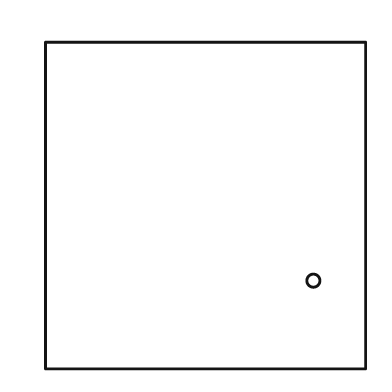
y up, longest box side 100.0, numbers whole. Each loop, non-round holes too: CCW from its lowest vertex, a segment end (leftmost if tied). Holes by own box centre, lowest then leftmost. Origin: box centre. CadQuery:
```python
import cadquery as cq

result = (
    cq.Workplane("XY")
    .moveTo(-49.0, -50.0)
    .lineTo(49.0, -50.0)
    .lineTo(49.0, 50.0)
    .lineTo(-49.0, 50.0)
    .close()
    .moveTo(33.0, -23.0)
    .circle(2.0)
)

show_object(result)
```